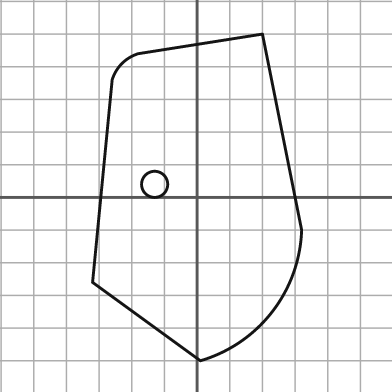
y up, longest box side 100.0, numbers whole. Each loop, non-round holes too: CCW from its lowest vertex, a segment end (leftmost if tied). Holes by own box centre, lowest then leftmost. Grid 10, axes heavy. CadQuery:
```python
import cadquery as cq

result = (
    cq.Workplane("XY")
    .moveTo(1.0, -50.0)
    .threePointArc((23.0, -35.0), (32.0, -10.0))
    .lineTo(20.0, 50.0)
    .lineTo(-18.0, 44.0)
    .threePointArc((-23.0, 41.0), (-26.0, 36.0))
    .lineTo(-32.0, -26.0)
    .close()
    .moveTo(-13.0, 4.0)
    .circle(4.0)
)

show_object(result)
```